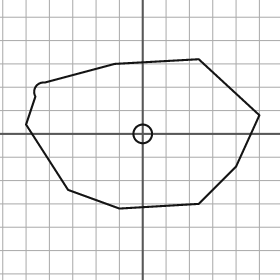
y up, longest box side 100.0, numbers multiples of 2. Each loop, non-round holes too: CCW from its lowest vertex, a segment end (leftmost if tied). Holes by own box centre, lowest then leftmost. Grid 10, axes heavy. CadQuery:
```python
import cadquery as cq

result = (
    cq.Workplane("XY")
    .moveTo(-10.0, -32.0)
    .lineTo(24.0, -30.0)
    .lineTo(40.0, -14.0)
    .lineTo(50.0, 8.0)
    .lineTo(24.0, 32.0)
    .lineTo(-12.0, 30.0)
    .lineTo(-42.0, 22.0)
    .threePointArc((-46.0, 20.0), (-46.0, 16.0))
    .lineTo(-50.0, 4.0)
    .lineTo(-32.0, -24.0)
    .close()
    .moveTo(0.0, 0.0)
    .circle(4.0)
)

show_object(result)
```